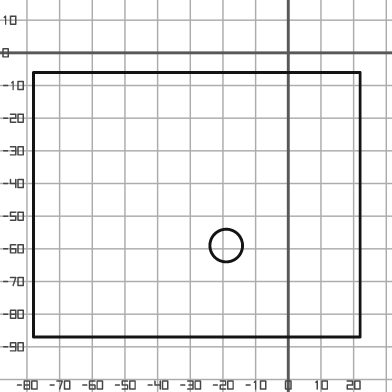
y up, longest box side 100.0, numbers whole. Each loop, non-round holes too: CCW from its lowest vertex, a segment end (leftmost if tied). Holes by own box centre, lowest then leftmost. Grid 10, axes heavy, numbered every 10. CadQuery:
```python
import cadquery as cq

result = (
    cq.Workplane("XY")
    .moveTo(-78.0, -87.0)
    .lineTo(22.0, -87.0)
    .lineTo(22.0, -6.0)
    .lineTo(-78.0, -6.0)
    .close()
    .moveTo(-19.0, -59.0)
    .circle(5.0)
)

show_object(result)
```